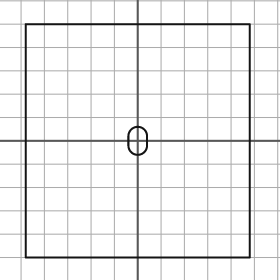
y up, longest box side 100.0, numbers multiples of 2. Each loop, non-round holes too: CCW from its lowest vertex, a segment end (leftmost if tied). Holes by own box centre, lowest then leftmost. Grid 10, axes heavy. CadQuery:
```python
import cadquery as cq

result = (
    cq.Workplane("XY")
    .moveTo(-48.0, -50.0)
    .lineTo(48.0, -50.0)
    .lineTo(48.0, 50.0)
    .lineTo(-48.0, 50.0)
    .close()
    .moveTo(-4.0, -2.0)
    .threePointArc((0.0, -6.0), (4.0, -2.0))
    .lineTo(4.0, 2.0)
    .threePointArc((0.0, 6.0), (-4.0, 2.0))
    .close()
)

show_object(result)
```